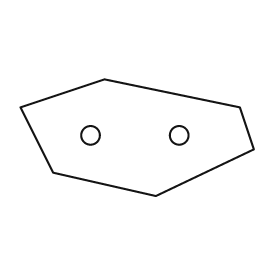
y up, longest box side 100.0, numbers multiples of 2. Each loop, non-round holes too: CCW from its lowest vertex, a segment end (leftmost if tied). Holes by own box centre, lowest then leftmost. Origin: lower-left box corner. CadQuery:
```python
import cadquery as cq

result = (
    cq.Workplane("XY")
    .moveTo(58.0, 0.0)
    .lineTo(100.0, 20.0)
    .lineTo(94.0, 38.0)
    .lineTo(36.0, 50.0)
    .lineTo(0.0, 38.0)
    .lineTo(14.0, 10.0)
    .close()
    .moveTo(30.0, 26.0)
    .circle(4.0)
    .moveTo(68.0, 26.0)
    .circle(4.0)
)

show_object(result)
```